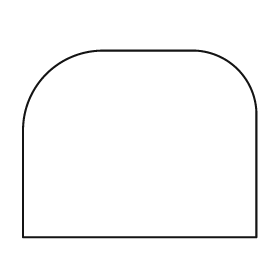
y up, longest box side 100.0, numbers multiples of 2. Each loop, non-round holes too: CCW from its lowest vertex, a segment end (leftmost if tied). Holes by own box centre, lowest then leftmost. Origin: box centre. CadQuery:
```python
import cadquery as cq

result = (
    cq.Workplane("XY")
    .moveTo(-50.0, -40.0)
    .lineTo(50.0, -40.0)
    .lineTo(50.0, 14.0)
    .threePointArc((42.0, 32.0), (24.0, 40.0))
    .lineTo(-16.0, 40.0)
    .threePointArc((-40.0, 30.0), (-50.0, 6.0))
    .close()
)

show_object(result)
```